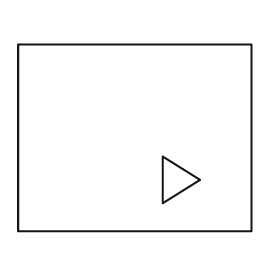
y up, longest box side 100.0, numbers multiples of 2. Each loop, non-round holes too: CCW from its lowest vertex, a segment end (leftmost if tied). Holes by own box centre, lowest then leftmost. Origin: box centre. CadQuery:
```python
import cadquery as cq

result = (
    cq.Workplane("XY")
    .moveTo(-50.0, -40.0)
    .lineTo(50.0, -40.0)
    .lineTo(50.0, 40.0)
    .lineTo(-50.0, 40.0)
    .close()
    .moveTo(12.0, -28.0)
    .lineTo(28.0, -18.0)
    .lineTo(12.0, -8.0)
    .close()
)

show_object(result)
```